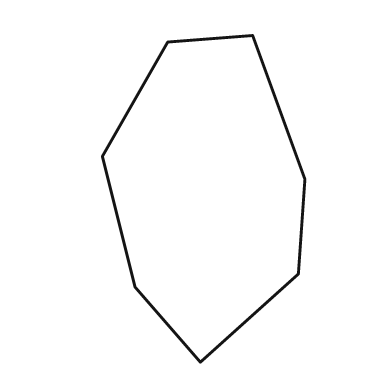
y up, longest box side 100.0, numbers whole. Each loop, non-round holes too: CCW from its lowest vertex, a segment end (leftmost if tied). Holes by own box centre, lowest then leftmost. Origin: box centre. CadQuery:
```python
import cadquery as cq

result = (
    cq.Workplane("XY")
    .moveTo(-1.0, -50.0)
    .lineTo(29.0, -23.0)
    .lineTo(31.0, 6.0)
    .lineTo(15.0, 50.0)
    .lineTo(-11.0, 48.0)
    .lineTo(-31.0, 13.0)
    .lineTo(-21.0, -27.0)
    .close()
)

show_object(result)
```